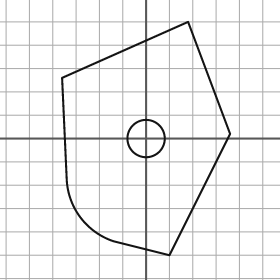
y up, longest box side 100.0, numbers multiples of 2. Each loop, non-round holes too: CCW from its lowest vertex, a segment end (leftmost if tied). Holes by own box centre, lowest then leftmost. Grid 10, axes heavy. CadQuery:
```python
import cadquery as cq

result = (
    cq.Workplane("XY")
    .moveTo(10.0, -50.0)
    .lineTo(36.0, 2.0)
    .lineTo(18.0, 50.0)
    .lineTo(-36.0, 26.0)
    .lineTo(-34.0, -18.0)
    .threePointArc((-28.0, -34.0), (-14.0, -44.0))
    .close()
    .moveTo(0.0, 0.0)
    .circle(8.0)
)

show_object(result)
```